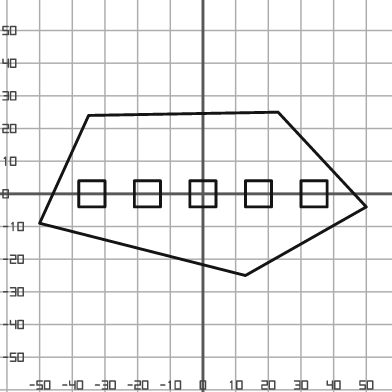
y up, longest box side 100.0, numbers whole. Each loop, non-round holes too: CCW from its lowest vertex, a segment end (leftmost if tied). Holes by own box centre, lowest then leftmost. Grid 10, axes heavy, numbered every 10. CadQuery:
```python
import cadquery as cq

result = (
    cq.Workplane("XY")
    .moveTo(13.0, -25.0)
    .lineTo(50.0, -4.0)
    .lineTo(23.0, 25.0)
    .lineTo(-35.0, 24.0)
    .lineTo(-50.0, -9.0)
    .close()
    .moveTo(-38.0, -4.0)
    .lineTo(-30.0, -4.0)
    .lineTo(-30.0, 4.0)
    .lineTo(-38.0, 4.0)
    .close()
    .moveTo(-21.0, -4.0)
    .lineTo(-13.0, -4.0)
    .lineTo(-13.0, 4.0)
    .lineTo(-21.0, 4.0)
    .close()
    .moveTo(-4.0, -4.0)
    .lineTo(4.0, -4.0)
    .lineTo(4.0, 4.0)
    .lineTo(-4.0, 4.0)
    .close()
    .moveTo(13.0, -4.0)
    .lineTo(21.0, -4.0)
    .lineTo(21.0, 4.0)
    .lineTo(13.0, 4.0)
    .close()
    .moveTo(30.0, -4.0)
    .lineTo(38.0, -4.0)
    .lineTo(38.0, 4.0)
    .lineTo(30.0, 4.0)
    .close()
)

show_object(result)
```